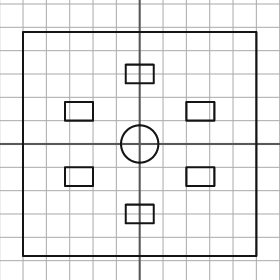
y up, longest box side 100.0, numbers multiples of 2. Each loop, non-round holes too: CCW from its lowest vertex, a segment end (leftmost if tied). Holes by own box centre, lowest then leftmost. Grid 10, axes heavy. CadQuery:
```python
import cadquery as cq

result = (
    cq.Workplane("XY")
    .moveTo(-50.0, -48.0)
    .lineTo(50.0, -48.0)
    .lineTo(50.0, 48.0)
    .lineTo(-50.0, 48.0)
    .close()
    .moveTo(-6.0, -34.0)
    .lineTo(6.0, -34.0)
    .lineTo(6.0, -26.0)
    .lineTo(-6.0, -26.0)
    .close()
    .moveTo(-32.0, -18.0)
    .lineTo(-20.0, -18.0)
    .lineTo(-20.0, -10.0)
    .lineTo(-32.0, -10.0)
    .close()
    .moveTo(20.0, -18.0)
    .lineTo(32.0, -18.0)
    .lineTo(32.0, -10.0)
    .lineTo(20.0, -10.0)
    .close()
    .moveTo(0.0, 0.0)
    .circle(8.0)
    .moveTo(-32.0, 10.0)
    .lineTo(-20.0, 10.0)
    .lineTo(-20.0, 18.0)
    .lineTo(-32.0, 18.0)
    .close()
    .moveTo(20.0, 10.0)
    .lineTo(32.0, 10.0)
    .lineTo(32.0, 18.0)
    .lineTo(20.0, 18.0)
    .close()
    .moveTo(-6.0, 26.0)
    .lineTo(6.0, 26.0)
    .lineTo(6.0, 34.0)
    .lineTo(-6.0, 34.0)
    .close()
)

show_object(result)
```